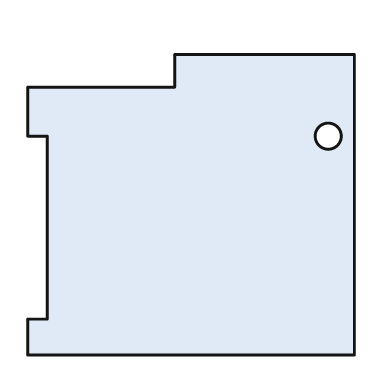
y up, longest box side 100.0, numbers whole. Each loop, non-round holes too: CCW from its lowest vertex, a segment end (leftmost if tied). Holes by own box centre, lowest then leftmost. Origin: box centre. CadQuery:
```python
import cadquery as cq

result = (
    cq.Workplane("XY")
    .moveTo(-50.0, -46.0)
    .lineTo(50.0, -46.0)
    .lineTo(50.0, 46.0)
    .lineTo(-5.0, 46.0)
    .lineTo(-5.0, 36.0)
    .lineTo(-50.0, 36.0)
    .lineTo(-50.0, 21.0)
    .lineTo(-44.0, 21.0)
    .lineTo(-44.0, -35.0)
    .lineTo(-50.0, -35.0)
    .close()
    .moveTo(42.0, 21.0)
    .circle(4.0)
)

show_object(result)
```